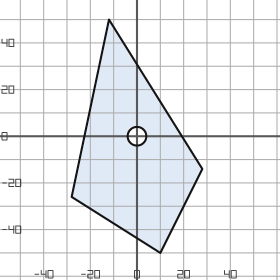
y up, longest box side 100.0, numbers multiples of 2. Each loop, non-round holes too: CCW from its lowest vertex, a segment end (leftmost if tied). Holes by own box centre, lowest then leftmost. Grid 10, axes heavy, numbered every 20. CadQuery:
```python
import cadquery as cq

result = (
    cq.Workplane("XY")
    .moveTo(10.0, -50.0)
    .lineTo(28.0, -14.0)
    .lineTo(-12.0, 50.0)
    .lineTo(-28.0, -26.0)
    .close()
    .moveTo(0.0, 0.0)
    .circle(4.0)
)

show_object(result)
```